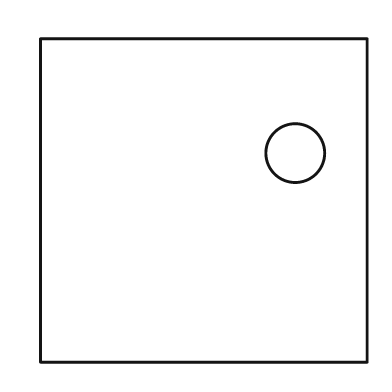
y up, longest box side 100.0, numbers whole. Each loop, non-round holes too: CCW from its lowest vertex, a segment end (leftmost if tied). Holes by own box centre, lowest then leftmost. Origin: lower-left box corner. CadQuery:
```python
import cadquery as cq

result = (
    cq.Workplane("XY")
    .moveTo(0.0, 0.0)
    .lineTo(100.0, 0.0)
    .lineTo(100.0, 99.0)
    .lineTo(0.0, 99.0)
    .close()
    .moveTo(78.0, 64.0)
    .circle(9.0)
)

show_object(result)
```